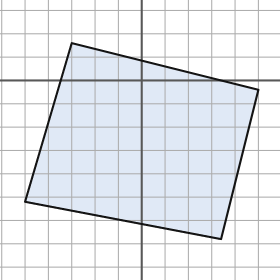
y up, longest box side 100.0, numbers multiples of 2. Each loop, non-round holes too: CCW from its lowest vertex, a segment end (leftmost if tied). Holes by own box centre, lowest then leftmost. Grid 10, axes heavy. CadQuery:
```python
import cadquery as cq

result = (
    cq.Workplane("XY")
    .moveTo(34.0, -68.0)
    .lineTo(50.0, -4.0)
    .lineTo(-30.0, 16.0)
    .lineTo(-50.0, -52.0)
    .close()
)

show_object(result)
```